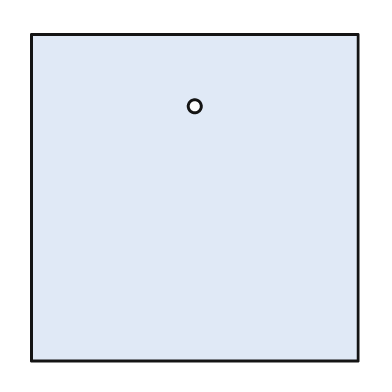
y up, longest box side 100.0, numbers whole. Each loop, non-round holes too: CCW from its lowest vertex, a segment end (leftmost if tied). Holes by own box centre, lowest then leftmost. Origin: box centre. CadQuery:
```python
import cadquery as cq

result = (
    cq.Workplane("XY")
    .moveTo(-50.0, -50.0)
    .lineTo(50.0, -50.0)
    .lineTo(50.0, 50.0)
    .lineTo(-50.0, 50.0)
    .close()
    .moveTo(0.0, 28.0)
    .circle(2.0)
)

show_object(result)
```